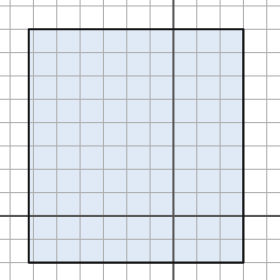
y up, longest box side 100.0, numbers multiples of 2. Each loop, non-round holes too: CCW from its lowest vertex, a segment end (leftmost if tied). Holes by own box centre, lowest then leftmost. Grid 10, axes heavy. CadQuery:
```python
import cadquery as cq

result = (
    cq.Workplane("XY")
    .moveTo(-62.0, -20.0)
    .lineTo(30.0, -20.0)
    .lineTo(30.0, 80.0)
    .lineTo(-62.0, 80.0)
    .close()
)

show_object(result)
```